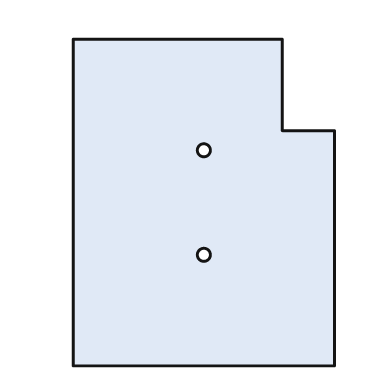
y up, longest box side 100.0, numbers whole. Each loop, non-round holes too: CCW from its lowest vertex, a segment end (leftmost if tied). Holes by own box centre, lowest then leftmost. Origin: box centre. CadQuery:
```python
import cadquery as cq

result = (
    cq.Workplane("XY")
    .moveTo(-40.0, -50.0)
    .lineTo(40.0, -50.0)
    .lineTo(40.0, 22.0)
    .lineTo(24.0, 22.0)
    .lineTo(24.0, 50.0)
    .lineTo(-40.0, 50.0)
    .close()
    .moveTo(0.0, -16.0)
    .circle(2.0)
    .moveTo(0.0, 16.0)
    .circle(2.0)
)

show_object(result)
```